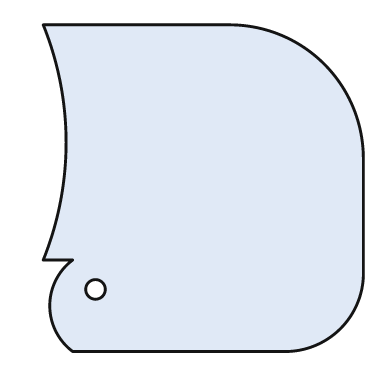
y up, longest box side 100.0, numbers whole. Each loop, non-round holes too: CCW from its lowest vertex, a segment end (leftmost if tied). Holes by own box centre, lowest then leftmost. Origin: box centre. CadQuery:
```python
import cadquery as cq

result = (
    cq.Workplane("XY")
    .moveTo(-40.0, -50.0)
    .lineTo(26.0, -50.0)
    .threePointArc((42.0, -43.0), (49.0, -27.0))
    .lineTo(49.0, 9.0)
    .threePointArc((37.0, 38.0), (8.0, 50.0))
    .lineTo(-49.0, 50.0)
    .threePointArc((-42.0, 14.0), (-49.0, -22.0))
    .lineTo(-40.0, -22.0)
    .threePointArc((-47.0, -36.0), (-40.0, -50.0))
    .close()
    .moveTo(-33.0, -31.0)
    .circle(3.0)
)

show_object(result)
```